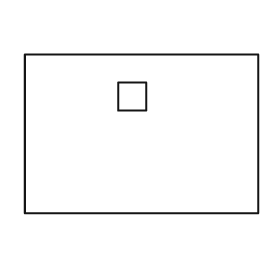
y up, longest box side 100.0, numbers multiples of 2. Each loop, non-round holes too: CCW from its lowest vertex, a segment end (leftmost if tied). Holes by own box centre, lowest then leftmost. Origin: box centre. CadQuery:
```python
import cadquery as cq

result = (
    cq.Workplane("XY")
    .moveTo(-50.0, -34.0)
    .lineTo(50.0, -34.0)
    .lineTo(50.0, 34.0)
    .lineTo(-50.0, 34.0)
    .close()
    .moveTo(-10.0, 10.0)
    .lineTo(2.0, 10.0)
    .lineTo(2.0, 22.0)
    .lineTo(-10.0, 22.0)
    .close()
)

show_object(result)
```